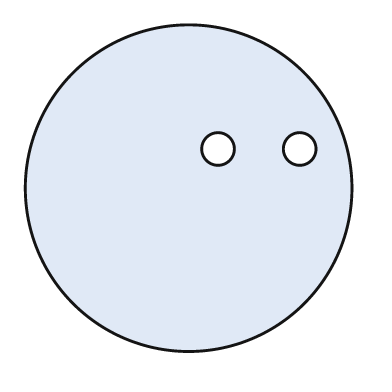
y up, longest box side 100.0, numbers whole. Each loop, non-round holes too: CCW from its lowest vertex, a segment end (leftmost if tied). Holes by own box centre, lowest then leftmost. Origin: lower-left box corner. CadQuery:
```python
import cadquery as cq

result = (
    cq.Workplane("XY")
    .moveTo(50.0, 50.0)
    .circle(50.0)
    .moveTo(59.0, 62.0)
    .circle(5.0)
    .moveTo(84.0, 62.0)
    .circle(5.0)
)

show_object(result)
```